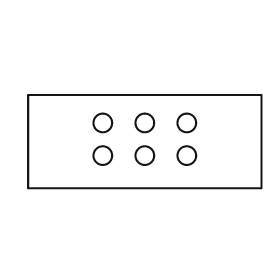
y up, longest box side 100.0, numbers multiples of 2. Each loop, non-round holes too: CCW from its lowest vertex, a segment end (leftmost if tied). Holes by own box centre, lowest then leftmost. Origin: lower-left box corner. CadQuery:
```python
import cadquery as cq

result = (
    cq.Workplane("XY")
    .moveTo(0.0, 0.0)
    .lineTo(100.0, 0.0)
    .lineTo(100.0, 40.0)
    .lineTo(0.0, 40.0)
    .close()
    .moveTo(32.0, 14.0)
    .circle(4.0)
    .moveTo(50.0, 14.0)
    .circle(4.0)
    .moveTo(68.0, 14.0)
    .circle(4.0)
    .moveTo(32.0, 28.0)
    .circle(4.0)
    .moveTo(50.0, 28.0)
    .circle(4.0)
    .moveTo(68.0, 28.0)
    .circle(4.0)
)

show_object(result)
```